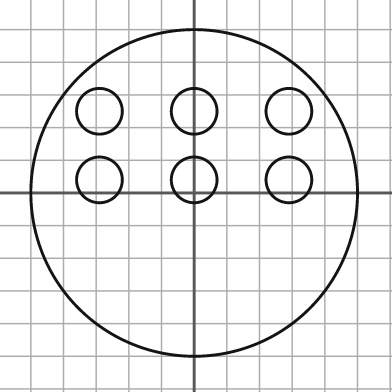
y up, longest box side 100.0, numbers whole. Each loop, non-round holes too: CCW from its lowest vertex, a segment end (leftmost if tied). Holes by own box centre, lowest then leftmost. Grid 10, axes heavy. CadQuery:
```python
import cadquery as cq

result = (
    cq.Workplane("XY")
    .moveTo(0.0, 0.0)
    .circle(50.0)
    .moveTo(-29.0, 4.0)
    .circle(7.0)
    .moveTo(0.0, 4.0)
    .circle(7.0)
    .moveTo(29.0, 4.0)
    .circle(7.0)
    .moveTo(-29.0, 25.0)
    .circle(7.0)
    .moveTo(0.0, 25.0)
    .circle(7.0)
    .moveTo(29.0, 25.0)
    .circle(7.0)
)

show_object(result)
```